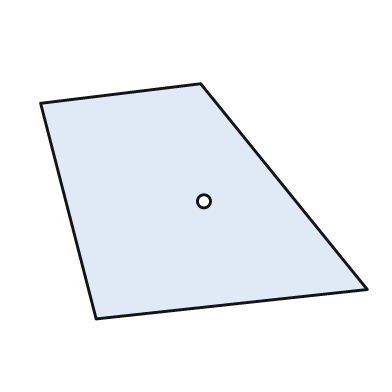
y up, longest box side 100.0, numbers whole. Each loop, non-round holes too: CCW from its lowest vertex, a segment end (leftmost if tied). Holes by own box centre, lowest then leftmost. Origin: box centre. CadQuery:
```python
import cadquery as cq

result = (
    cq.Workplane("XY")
    .moveTo(-33.0, -36.0)
    .lineTo(50.0, -27.0)
    .lineTo(-1.0, 36.0)
    .lineTo(-50.0, 30.0)
    .close()
    .moveTo(0.0, 0.0)
    .circle(2.0)
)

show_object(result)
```